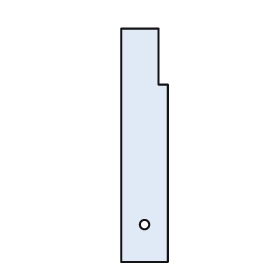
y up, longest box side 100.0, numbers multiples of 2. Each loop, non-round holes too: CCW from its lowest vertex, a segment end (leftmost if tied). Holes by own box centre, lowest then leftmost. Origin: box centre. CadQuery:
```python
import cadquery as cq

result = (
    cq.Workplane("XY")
    .moveTo(-10.0, -50.0)
    .lineTo(10.0, -50.0)
    .lineTo(10.0, 26.0)
    .lineTo(6.0, 26.0)
    .lineTo(6.0, 50.0)
    .lineTo(-10.0, 50.0)
    .close()
    .moveTo(0.0, -34.0)
    .circle(2.0)
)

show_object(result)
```